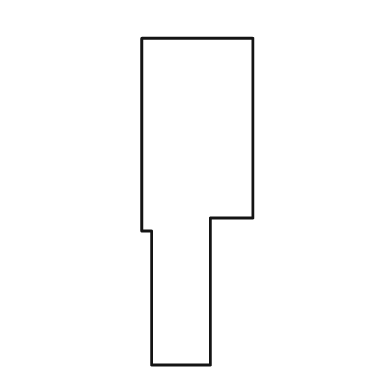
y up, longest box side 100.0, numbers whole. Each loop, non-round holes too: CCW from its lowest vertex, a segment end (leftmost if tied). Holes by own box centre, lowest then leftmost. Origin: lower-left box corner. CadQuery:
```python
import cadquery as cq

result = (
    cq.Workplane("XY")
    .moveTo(3.0, 0.0)
    .lineTo(21.0, 0.0)
    .lineTo(21.0, 45.0)
    .lineTo(34.0, 45.0)
    .lineTo(34.0, 100.0)
    .lineTo(0.0, 100.0)
    .lineTo(0.0, 41.0)
    .lineTo(3.0, 41.0)
    .close()
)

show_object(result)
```